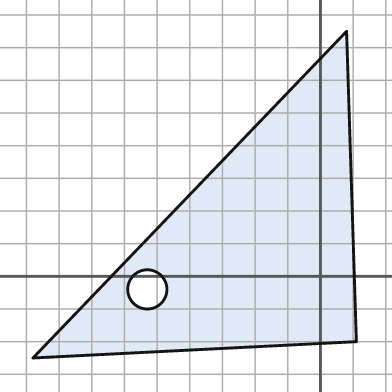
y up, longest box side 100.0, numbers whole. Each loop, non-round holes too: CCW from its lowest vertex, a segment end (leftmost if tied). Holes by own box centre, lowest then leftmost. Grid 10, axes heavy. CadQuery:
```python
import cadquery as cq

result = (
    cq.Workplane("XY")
    .moveTo(-88.0, -25.0)
    .lineTo(11.0, -20.0)
    .lineTo(8.0, 75.0)
    .close()
    .moveTo(-53.0, -4.0)
    .circle(6.0)
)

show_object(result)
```